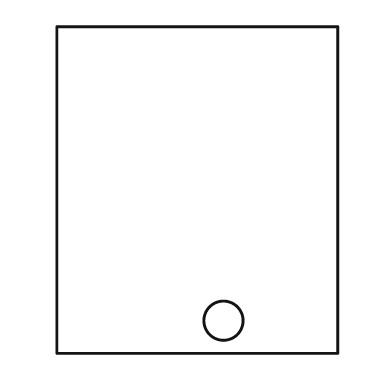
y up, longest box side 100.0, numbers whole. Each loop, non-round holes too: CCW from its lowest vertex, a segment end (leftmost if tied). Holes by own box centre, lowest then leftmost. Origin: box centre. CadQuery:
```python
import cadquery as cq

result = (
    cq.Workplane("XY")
    .moveTo(-43.0, -50.0)
    .lineTo(43.0, -50.0)
    .lineTo(43.0, 50.0)
    .lineTo(-43.0, 50.0)
    .close()
    .moveTo(8.0, -40.0)
    .circle(6.0)
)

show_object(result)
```